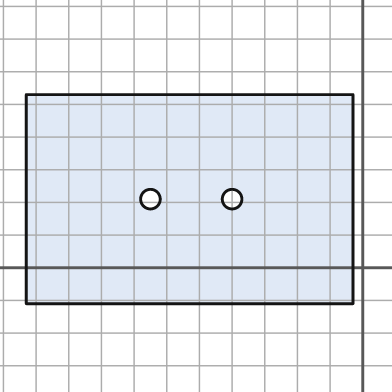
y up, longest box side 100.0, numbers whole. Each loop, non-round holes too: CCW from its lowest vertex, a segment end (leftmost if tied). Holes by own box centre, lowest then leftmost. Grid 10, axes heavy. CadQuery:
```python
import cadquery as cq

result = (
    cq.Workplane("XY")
    .moveTo(-103.0, -11.0)
    .lineTo(-3.0, -11.0)
    .lineTo(-3.0, 53.0)
    .lineTo(-103.0, 53.0)
    .close()
    .moveTo(-65.0, 21.0)
    .circle(3.0)
    .moveTo(-40.0, 21.0)
    .circle(3.0)
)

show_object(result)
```